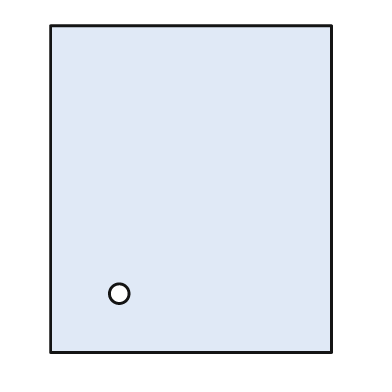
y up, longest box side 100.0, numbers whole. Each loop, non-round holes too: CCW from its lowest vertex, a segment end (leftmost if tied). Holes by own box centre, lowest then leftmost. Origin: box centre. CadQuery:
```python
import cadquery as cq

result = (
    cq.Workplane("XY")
    .moveTo(-43.0, -50.0)
    .lineTo(43.0, -50.0)
    .lineTo(43.0, 50.0)
    .lineTo(-43.0, 50.0)
    .close()
    .moveTo(-22.0, -32.0)
    .circle(3.0)
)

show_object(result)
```